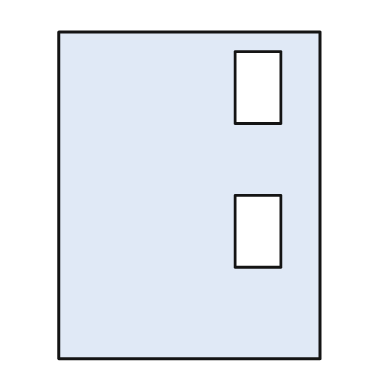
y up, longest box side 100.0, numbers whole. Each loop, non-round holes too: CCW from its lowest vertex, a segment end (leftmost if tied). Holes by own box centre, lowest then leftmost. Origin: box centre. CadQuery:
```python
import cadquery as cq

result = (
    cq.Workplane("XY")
    .moveTo(-40.0, -50.0)
    .lineTo(40.0, -50.0)
    .lineTo(40.0, 50.0)
    .lineTo(-40.0, 50.0)
    .close()
    .moveTo(14.0, -22.0)
    .lineTo(28.0, -22.0)
    .lineTo(28.0, 0.0)
    .lineTo(14.0, 0.0)
    .close()
    .moveTo(14.0, 22.0)
    .lineTo(28.0, 22.0)
    .lineTo(28.0, 44.0)
    .lineTo(14.0, 44.0)
    .close()
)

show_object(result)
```